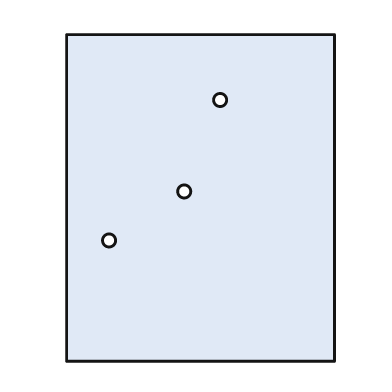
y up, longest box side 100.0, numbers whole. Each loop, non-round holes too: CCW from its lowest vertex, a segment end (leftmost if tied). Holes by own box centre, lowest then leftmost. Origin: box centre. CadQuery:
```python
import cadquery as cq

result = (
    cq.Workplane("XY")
    .moveTo(-41.0, -50.0)
    .lineTo(41.0, -50.0)
    .lineTo(41.0, 50.0)
    .lineTo(-41.0, 50.0)
    .close()
    .moveTo(-28.0, -13.0)
    .circle(2.0)
    .moveTo(-5.0, 2.0)
    .circle(2.0)
    .moveTo(6.0, 30.0)
    .circle(2.0)
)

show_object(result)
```